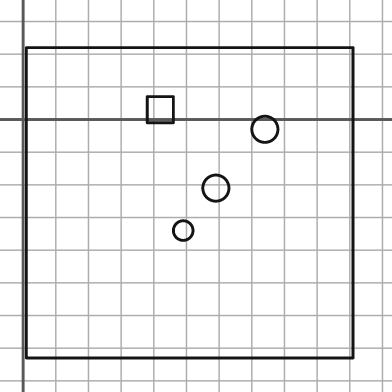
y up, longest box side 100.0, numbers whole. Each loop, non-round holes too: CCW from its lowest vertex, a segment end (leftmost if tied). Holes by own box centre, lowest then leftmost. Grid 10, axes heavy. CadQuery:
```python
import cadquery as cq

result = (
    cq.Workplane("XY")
    .moveTo(1.0, -73.0)
    .lineTo(101.0, -73.0)
    .lineTo(101.0, 22.0)
    .lineTo(1.0, 22.0)
    .close()
    .moveTo(49.0, -34.0)
    .circle(3.0)
    .moveTo(59.0, -21.0)
    .circle(4.0)
    .moveTo(74.0, -3.0)
    .circle(4.0)
    .moveTo(38.0, -1.0)
    .lineTo(46.0, -1.0)
    .lineTo(46.0, 7.0)
    .lineTo(38.0, 7.0)
    .close()
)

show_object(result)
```